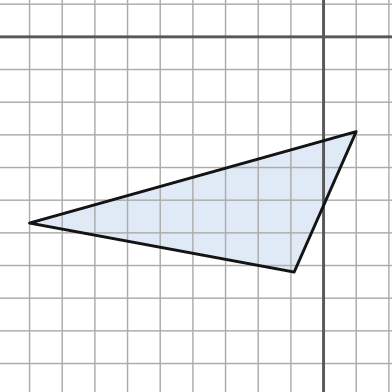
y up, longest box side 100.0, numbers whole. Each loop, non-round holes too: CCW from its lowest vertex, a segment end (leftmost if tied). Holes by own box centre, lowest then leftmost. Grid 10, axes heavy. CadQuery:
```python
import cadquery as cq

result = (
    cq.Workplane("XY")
    .moveTo(-9.0, -72.0)
    .lineTo(10.0, -29.0)
    .lineTo(-90.0, -57.0)
    .close()
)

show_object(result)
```